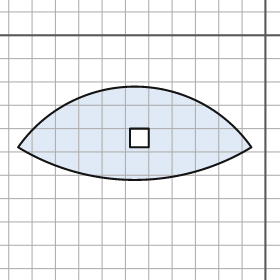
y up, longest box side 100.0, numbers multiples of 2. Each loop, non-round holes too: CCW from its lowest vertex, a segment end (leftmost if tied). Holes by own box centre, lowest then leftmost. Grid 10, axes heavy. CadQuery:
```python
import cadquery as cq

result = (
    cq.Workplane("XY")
    .moveTo(-106.0, -48.0)
    .threePointArc((-56.0, -62.0), (-6.0, -48.0))
    .threePointArc((-56.0, -22.0), (-106.0, -48.0))
    .close()
    .moveTo(-58.0, -48.0)
    .lineTo(-50.0, -48.0)
    .lineTo(-50.0, -40.0)
    .lineTo(-58.0, -40.0)
    .close()
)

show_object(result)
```